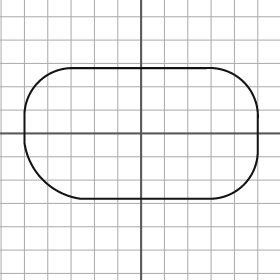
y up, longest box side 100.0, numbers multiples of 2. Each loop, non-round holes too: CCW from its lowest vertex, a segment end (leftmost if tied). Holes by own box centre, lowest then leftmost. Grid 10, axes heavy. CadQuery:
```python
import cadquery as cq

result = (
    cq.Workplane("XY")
    .moveTo(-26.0, -28.0)
    .lineTo(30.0, -28.0)
    .threePointArc((44.0, -22.0), (50.0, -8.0))
    .lineTo(50.0, 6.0)
    .threePointArc((44.0, 22.0), (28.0, 28.0))
    .lineTo(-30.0, 28.0)
    .threePointArc((-44.0, 22.0), (-50.0, 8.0))
    .lineTo(-50.0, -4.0)
    .threePointArc((-42.0, -20.0), (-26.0, -28.0))
    .close()
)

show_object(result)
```